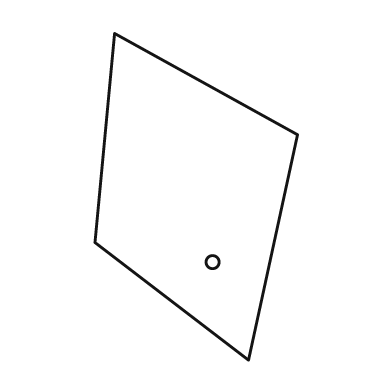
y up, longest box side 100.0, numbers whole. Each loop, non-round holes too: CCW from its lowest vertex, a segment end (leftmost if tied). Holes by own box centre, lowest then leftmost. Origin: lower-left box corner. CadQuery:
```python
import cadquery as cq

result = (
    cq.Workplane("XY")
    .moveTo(47.0, 0.0)
    .lineTo(62.0, 69.0)
    .lineTo(6.0, 100.0)
    .lineTo(0.0, 36.0)
    .close()
    .moveTo(36.0, 30.0)
    .circle(2.0)
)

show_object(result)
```